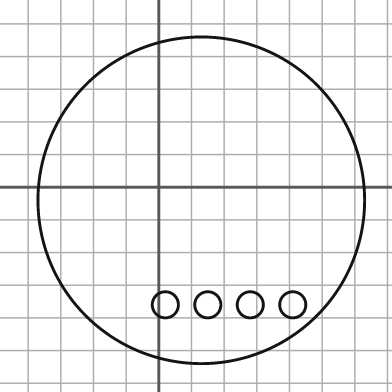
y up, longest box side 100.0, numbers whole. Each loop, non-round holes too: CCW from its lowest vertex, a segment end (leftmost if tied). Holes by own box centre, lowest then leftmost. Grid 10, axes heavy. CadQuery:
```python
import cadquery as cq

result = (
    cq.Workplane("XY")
    .moveTo(13.0, -4.0)
    .circle(50.0)
    .moveTo(2.0, -36.0)
    .circle(4.0)
    .moveTo(15.0, -36.0)
    .circle(4.0)
    .moveTo(28.0, -36.0)
    .circle(4.0)
    .moveTo(41.0, -36.0)
    .circle(4.0)
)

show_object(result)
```